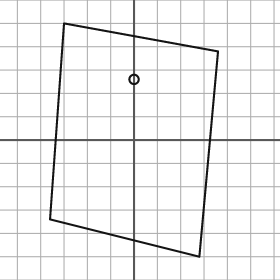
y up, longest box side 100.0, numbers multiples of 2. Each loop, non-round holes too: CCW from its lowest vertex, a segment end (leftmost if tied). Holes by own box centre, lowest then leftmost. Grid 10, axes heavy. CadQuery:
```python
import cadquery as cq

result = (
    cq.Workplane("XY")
    .moveTo(28.0, -50.0)
    .lineTo(36.0, 38.0)
    .lineTo(-30.0, 50.0)
    .lineTo(-36.0, -34.0)
    .close()
    .moveTo(0.0, 26.0)
    .circle(2.0)
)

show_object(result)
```